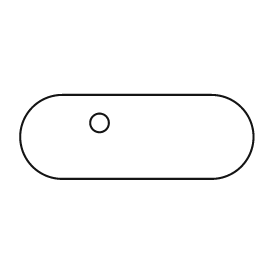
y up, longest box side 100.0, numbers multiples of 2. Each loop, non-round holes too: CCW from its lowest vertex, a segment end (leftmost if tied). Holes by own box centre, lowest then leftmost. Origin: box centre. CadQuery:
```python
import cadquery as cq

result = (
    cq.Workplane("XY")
    .moveTo(-32.0, -18.0)
    .lineTo(32.0, -18.0)
    .threePointArc((50.0, 0.0), (32.0, 18.0))
    .lineTo(-32.0, 18.0)
    .threePointArc((-50.0, 0.0), (-32.0, -18.0))
    .close()
    .moveTo(-16.0, 6.0)
    .circle(4.0)
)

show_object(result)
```